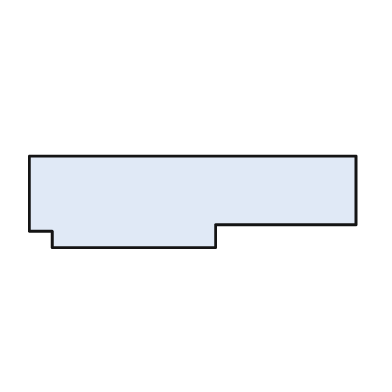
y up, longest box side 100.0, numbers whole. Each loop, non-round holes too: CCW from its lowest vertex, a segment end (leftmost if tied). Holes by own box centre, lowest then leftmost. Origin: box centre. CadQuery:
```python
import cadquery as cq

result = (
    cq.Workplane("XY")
    .moveTo(-43.0, -14.0)
    .lineTo(7.0, -14.0)
    .lineTo(7.0, -7.0)
    .lineTo(50.0, -7.0)
    .lineTo(50.0, 14.0)
    .lineTo(-50.0, 14.0)
    .lineTo(-50.0, -9.0)
    .lineTo(-43.0, -9.0)
    .close()
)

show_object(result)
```